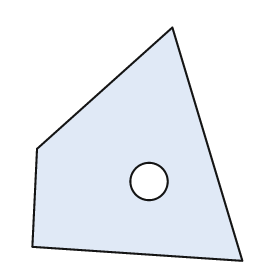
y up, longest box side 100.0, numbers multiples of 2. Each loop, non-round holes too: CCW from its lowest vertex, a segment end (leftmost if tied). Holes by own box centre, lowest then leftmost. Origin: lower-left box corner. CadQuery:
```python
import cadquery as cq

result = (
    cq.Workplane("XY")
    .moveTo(90.0, 0.0)
    .lineTo(60.0, 100.0)
    .lineTo(2.0, 48.0)
    .lineTo(0.0, 6.0)
    .close()
    .moveTo(50.0, 34.0)
    .circle(8.0)
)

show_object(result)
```